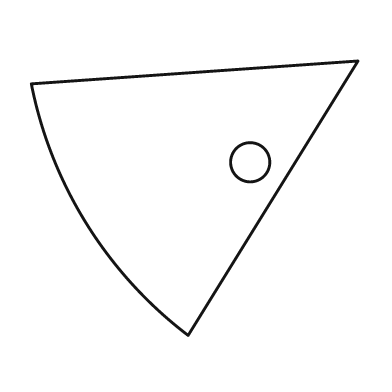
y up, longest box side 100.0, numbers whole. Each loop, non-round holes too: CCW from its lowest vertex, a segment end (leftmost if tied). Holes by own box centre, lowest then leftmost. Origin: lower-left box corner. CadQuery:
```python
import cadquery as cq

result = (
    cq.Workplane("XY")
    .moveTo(48.0, 0.0)
    .lineTo(100.0, 84.0)
    .lineTo(0.0, 77.0)
    .threePointArc((17.0, 34.0), (48.0, 0.0))
    .close()
    .moveTo(67.0, 53.0)
    .circle(6.0)
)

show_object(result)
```